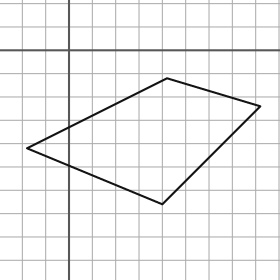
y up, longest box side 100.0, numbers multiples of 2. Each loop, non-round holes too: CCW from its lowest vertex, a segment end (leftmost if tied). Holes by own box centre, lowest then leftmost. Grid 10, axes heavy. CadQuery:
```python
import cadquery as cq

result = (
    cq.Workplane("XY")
    .moveTo(40.0, -66.0)
    .lineTo(82.0, -24.0)
    .lineTo(42.0, -12.0)
    .lineTo(-18.0, -42.0)
    .close()
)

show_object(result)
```